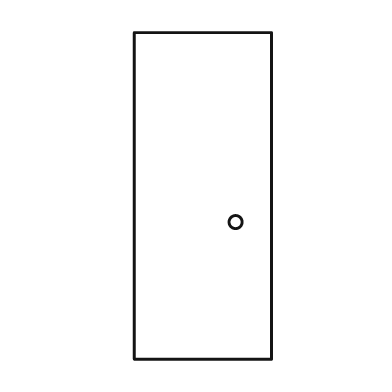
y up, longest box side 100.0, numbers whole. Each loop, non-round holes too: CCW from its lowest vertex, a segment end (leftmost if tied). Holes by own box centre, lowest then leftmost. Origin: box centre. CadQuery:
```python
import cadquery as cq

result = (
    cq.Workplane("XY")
    .moveTo(-21.0, -50.0)
    .lineTo(21.0, -50.0)
    .lineTo(21.0, 50.0)
    .lineTo(-21.0, 50.0)
    .close()
    .moveTo(10.0, -8.0)
    .circle(2.0)
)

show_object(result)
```